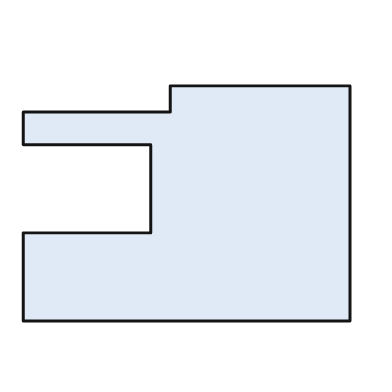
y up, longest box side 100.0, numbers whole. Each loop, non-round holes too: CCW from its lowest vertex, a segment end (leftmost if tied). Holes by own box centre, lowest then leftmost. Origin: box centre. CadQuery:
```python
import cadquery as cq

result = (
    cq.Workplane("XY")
    .moveTo(-50.0, -36.0)
    .lineTo(50.0, -36.0)
    .lineTo(50.0, 36.0)
    .lineTo(-5.0, 36.0)
    .lineTo(-5.0, 28.0)
    .lineTo(-50.0, 28.0)
    .lineTo(-50.0, 18.0)
    .lineTo(-11.0, 18.0)
    .lineTo(-11.0, -9.0)
    .lineTo(-50.0, -9.0)
    .close()
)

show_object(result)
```